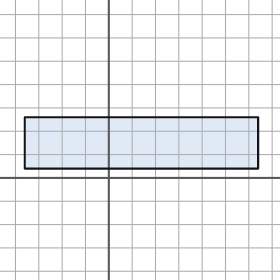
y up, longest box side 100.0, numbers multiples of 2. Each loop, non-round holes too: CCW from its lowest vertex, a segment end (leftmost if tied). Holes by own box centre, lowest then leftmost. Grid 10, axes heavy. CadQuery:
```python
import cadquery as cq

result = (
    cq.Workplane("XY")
    .moveTo(-36.0, 4.0)
    .lineTo(64.0, 4.0)
    .lineTo(64.0, 26.0)
    .lineTo(-36.0, 26.0)
    .close()
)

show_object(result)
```